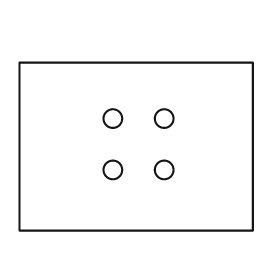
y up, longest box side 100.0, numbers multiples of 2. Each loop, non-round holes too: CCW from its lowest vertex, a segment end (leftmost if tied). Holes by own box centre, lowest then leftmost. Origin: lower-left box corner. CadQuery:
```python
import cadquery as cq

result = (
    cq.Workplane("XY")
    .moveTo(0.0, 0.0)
    .lineTo(100.0, 0.0)
    .lineTo(100.0, 72.0)
    .lineTo(0.0, 72.0)
    .close()
    .moveTo(40.0, 26.0)
    .circle(4.0)
    .moveTo(62.0, 26.0)
    .circle(4.0)
    .moveTo(40.0, 48.0)
    .circle(4.0)
    .moveTo(62.0, 48.0)
    .circle(4.0)
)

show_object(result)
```